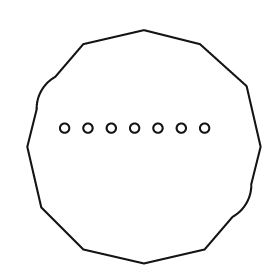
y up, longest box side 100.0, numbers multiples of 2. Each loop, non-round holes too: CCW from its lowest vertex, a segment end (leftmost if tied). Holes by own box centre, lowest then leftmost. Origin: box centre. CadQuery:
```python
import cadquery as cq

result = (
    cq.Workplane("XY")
    .moveTo(0.0, -50.0)
    .lineTo(26.0, -44.0)
    .lineTo(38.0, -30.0)
    .threePointArc((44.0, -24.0), (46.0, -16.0))
    .lineTo(50.0, 0.0)
    .lineTo(44.0, 26.0)
    .lineTo(24.0, 44.0)
    .lineTo(0.0, 50.0)
    .lineTo(-26.0, 44.0)
    .lineTo(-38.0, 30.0)
    .threePointArc((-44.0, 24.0), (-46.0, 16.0))
    .lineTo(-50.0, 0.0)
    .lineTo(-44.0, -26.0)
    .lineTo(-26.0, -44.0)
    .close()
    .moveTo(-34.0, 8.0)
    .circle(2.0)
    .moveTo(-24.0, 8.0)
    .circle(2.0)
    .moveTo(-14.0, 8.0)
    .circle(2.0)
    .moveTo(-4.0, 8.0)
    .circle(2.0)
    .moveTo(6.0, 8.0)
    .circle(2.0)
    .moveTo(16.0, 8.0)
    .circle(2.0)
    .moveTo(26.0, 8.0)
    .circle(2.0)
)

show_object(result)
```